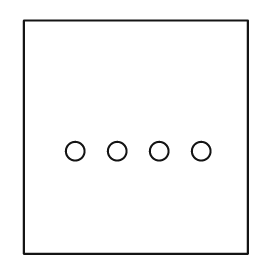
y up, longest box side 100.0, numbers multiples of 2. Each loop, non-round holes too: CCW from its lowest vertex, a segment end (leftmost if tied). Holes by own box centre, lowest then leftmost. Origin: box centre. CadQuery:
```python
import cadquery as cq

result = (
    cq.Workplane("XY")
    .moveTo(-48.0, -50.0)
    .lineTo(48.0, -50.0)
    .lineTo(48.0, 50.0)
    .lineTo(-48.0, 50.0)
    .close()
    .moveTo(-26.0, -6.0)
    .circle(4.0)
    .moveTo(-8.0, -6.0)
    .circle(4.0)
    .moveTo(10.0, -6.0)
    .circle(4.0)
    .moveTo(28.0, -6.0)
    .circle(4.0)
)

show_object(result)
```